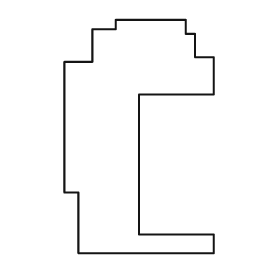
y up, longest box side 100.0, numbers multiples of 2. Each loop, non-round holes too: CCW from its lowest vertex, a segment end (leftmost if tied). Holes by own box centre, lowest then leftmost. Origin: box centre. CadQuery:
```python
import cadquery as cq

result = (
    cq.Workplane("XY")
    .moveTo(-26.0, -50.0)
    .lineTo(32.0, -50.0)
    .lineTo(32.0, -42.0)
    .lineTo(0.0, -42.0)
    .lineTo(0.0, 18.0)
    .lineTo(32.0, 18.0)
    .lineTo(32.0, 34.0)
    .lineTo(24.0, 34.0)
    .lineTo(24.0, 44.0)
    .lineTo(20.0, 44.0)
    .lineTo(20.0, 50.0)
    .lineTo(-10.0, 50.0)
    .lineTo(-10.0, 46.0)
    .lineTo(-20.0, 46.0)
    .lineTo(-20.0, 32.0)
    .lineTo(-32.0, 32.0)
    .lineTo(-32.0, -24.0)
    .lineTo(-26.0, -24.0)
    .close()
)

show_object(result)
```